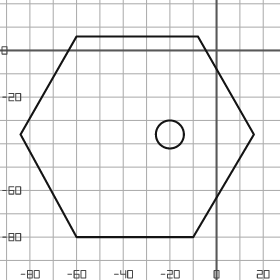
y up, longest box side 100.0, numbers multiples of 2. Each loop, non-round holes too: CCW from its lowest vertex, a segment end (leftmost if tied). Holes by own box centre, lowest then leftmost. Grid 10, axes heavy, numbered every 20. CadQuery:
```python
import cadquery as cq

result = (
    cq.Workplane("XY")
    .moveTo(-60.0, -80.0)
    .lineTo(-10.0, -80.0)
    .lineTo(16.0, -36.0)
    .lineTo(-8.0, 6.0)
    .lineTo(-60.0, 6.0)
    .lineTo(-84.0, -36.0)
    .close()
    .moveTo(-20.0, -36.0)
    .circle(6.0)
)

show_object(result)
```